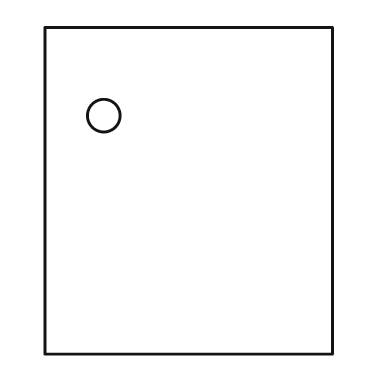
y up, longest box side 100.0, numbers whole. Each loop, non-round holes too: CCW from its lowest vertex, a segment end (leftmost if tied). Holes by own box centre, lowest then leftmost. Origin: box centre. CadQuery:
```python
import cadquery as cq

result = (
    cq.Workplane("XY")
    .moveTo(-44.0, -50.0)
    .lineTo(44.0, -50.0)
    .lineTo(44.0, 50.0)
    .lineTo(-44.0, 50.0)
    .close()
    .moveTo(-26.0, 23.0)
    .circle(5.0)
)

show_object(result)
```